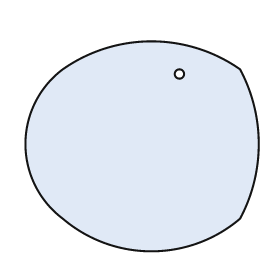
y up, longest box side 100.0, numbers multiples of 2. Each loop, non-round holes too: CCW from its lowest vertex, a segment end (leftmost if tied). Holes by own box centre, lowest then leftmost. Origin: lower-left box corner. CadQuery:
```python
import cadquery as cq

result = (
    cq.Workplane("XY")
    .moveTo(16.0, 14.0)
    .threePointArc((54.0, 0.0), (92.0, 14.0))
    .threePointArc((100.0, 46.0), (92.0, 78.0))
    .threePointArc((54.0, 90.0), (16.0, 78.0))
    .threePointArc((0.0, 46.0), (16.0, 14.0))
    .close()
    .moveTo(66.0, 76.0)
    .circle(2.0)
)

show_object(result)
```